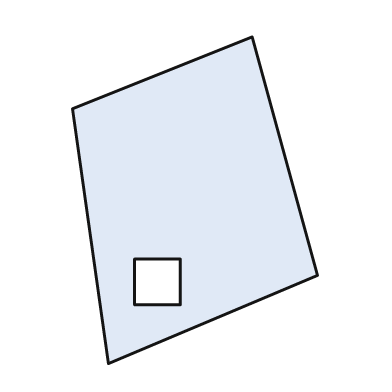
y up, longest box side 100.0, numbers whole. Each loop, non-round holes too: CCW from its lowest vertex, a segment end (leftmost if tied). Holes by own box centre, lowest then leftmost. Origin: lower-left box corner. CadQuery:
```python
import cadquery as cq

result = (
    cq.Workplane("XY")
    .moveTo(11.0, 0.0)
    .lineTo(75.0, 27.0)
    .lineTo(55.0, 100.0)
    .lineTo(0.0, 78.0)
    .close()
    .moveTo(19.0, 18.0)
    .lineTo(33.0, 18.0)
    .lineTo(33.0, 32.0)
    .lineTo(19.0, 32.0)
    .close()
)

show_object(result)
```